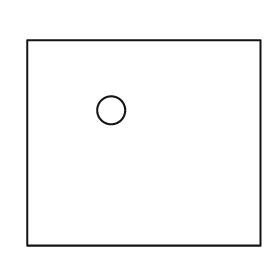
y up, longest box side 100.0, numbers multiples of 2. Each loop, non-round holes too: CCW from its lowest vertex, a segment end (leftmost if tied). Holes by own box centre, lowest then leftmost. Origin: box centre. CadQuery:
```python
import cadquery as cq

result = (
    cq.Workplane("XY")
    .moveTo(-50.0, -44.0)
    .lineTo(50.0, -44.0)
    .lineTo(50.0, 44.0)
    .lineTo(-50.0, 44.0)
    .close()
    .moveTo(-14.0, 14.0)
    .circle(6.0)
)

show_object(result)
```